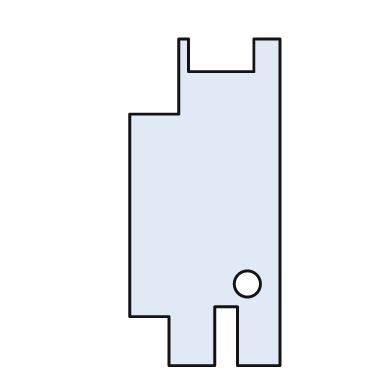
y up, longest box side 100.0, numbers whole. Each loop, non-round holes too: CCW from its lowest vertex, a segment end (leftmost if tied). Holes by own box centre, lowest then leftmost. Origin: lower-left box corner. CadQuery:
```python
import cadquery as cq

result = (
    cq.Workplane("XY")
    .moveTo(12.0, 0.0)
    .lineTo(26.0, 0.0)
    .lineTo(26.0, 18.0)
    .lineTo(33.0, 18.0)
    .lineTo(33.0, 0.0)
    .lineTo(46.0, 0.0)
    .lineTo(46.0, 100.0)
    .lineTo(38.0, 100.0)
    .lineTo(38.0, 90.0)
    .lineTo(18.0, 90.0)
    .lineTo(18.0, 100.0)
    .lineTo(15.0, 100.0)
    .lineTo(15.0, 77.0)
    .lineTo(0.0, 77.0)
    .lineTo(0.0, 15.0)
    .lineTo(12.0, 15.0)
    .close()
    .moveTo(36.0, 25.0)
    .circle(4.0)
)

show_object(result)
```